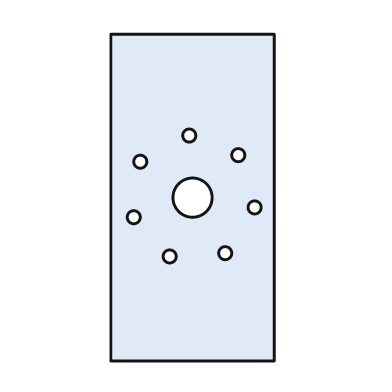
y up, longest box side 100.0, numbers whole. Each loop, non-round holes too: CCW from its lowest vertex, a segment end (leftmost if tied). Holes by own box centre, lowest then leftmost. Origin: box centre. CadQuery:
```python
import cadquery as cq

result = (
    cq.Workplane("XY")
    .moveTo(-25.0, -50.0)
    .lineTo(25.0, -50.0)
    .lineTo(25.0, 50.0)
    .lineTo(-25.0, 50.0)
    .close()
    .moveTo(-7.0, -18.0)
    .circle(2.0)
    .moveTo(10.0, -17.0)
    .circle(2.0)
    .moveTo(-18.0, -6.0)
    .circle(2.0)
    .moveTo(19.0, -3.0)
    .circle(2.0)
    .moveTo(0.0, 0.0)
    .circle(6.0)
    .moveTo(-16.0, 11.0)
    .circle(2.0)
    .moveTo(14.0, 13.0)
    .circle(2.0)
    .moveTo(-1.0, 19.0)
    .circle(2.0)
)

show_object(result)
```